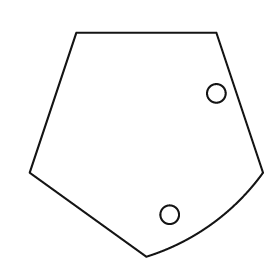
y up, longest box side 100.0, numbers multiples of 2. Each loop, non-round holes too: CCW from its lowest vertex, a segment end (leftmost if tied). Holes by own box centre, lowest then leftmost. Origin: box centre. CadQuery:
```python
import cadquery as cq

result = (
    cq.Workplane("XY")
    .moveTo(0.0, -48.0)
    .threePointArc((28.0, -34.0), (50.0, -12.0))
    .lineTo(30.0, 48.0)
    .lineTo(-30.0, 48.0)
    .lineTo(-50.0, -12.0)
    .close()
    .moveTo(10.0, -30.0)
    .circle(4.0)
    .moveTo(30.0, 22.0)
    .circle(4.0)
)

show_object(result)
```